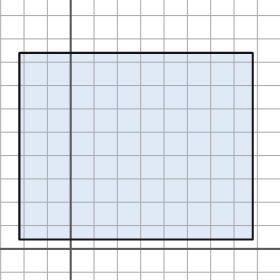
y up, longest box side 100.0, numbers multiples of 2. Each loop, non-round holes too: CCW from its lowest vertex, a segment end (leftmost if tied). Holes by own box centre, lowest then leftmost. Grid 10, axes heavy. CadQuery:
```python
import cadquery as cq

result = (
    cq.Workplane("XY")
    .moveTo(-22.0, 4.0)
    .lineTo(78.0, 4.0)
    .lineTo(78.0, 84.0)
    .lineTo(-22.0, 84.0)
    .close()
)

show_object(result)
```